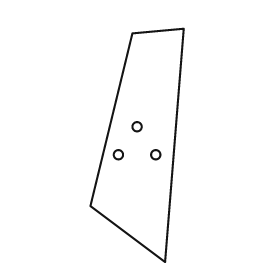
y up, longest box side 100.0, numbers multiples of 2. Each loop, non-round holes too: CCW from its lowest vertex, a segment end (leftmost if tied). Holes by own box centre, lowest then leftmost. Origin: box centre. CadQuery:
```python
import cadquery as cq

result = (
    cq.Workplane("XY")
    .moveTo(12.0, -50.0)
    .lineTo(20.0, 50.0)
    .lineTo(-2.0, 48.0)
    .lineTo(-20.0, -26.0)
    .close()
    .moveTo(-8.0, -4.0)
    .circle(2.0)
    .moveTo(8.0, -4.0)
    .circle(2.0)
    .moveTo(0.0, 8.0)
    .circle(2.0)
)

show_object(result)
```